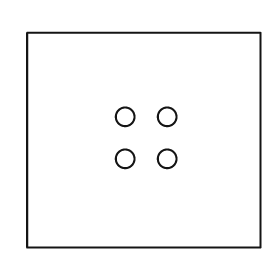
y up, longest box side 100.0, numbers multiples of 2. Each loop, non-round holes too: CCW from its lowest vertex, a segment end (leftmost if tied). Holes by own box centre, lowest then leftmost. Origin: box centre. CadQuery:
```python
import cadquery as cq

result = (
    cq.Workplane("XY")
    .moveTo(-50.0, -46.0)
    .lineTo(50.0, -46.0)
    .lineTo(50.0, 46.0)
    .lineTo(-50.0, 46.0)
    .close()
    .moveTo(-8.0, -8.0)
    .circle(4.0)
    .moveTo(10.0, -8.0)
    .circle(4.0)
    .moveTo(-8.0, 10.0)
    .circle(4.0)
    .moveTo(10.0, 10.0)
    .circle(4.0)
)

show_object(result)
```